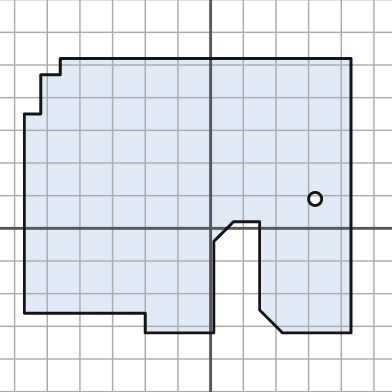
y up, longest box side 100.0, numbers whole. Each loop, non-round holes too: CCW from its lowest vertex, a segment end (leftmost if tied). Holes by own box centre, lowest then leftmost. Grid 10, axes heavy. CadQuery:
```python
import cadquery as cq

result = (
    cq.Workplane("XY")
    .moveTo(-20.0, -32.0)
    .lineTo(1.0, -32.0)
    .lineTo(1.0, -4.0)
    .lineTo(7.0, 2.0)
    .lineTo(15.0, 2.0)
    .lineTo(15.0, -25.0)
    .lineTo(22.0, -32.0)
    .lineTo(43.0, -32.0)
    .lineTo(43.0, 52.0)
    .lineTo(-46.0, 52.0)
    .lineTo(-46.0, 47.0)
    .lineTo(-52.0, 47.0)
    .lineTo(-52.0, 35.0)
    .lineTo(-57.0, 35.0)
    .lineTo(-57.0, -26.0)
    .lineTo(-20.0, -26.0)
    .close()
    .moveTo(32.0, 9.0)
    .circle(2.0)
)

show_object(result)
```